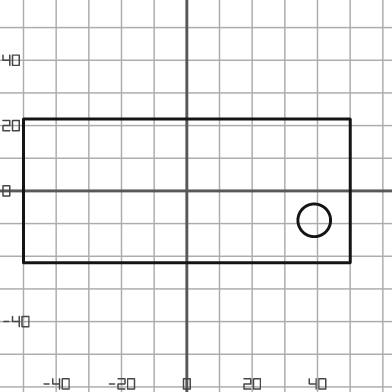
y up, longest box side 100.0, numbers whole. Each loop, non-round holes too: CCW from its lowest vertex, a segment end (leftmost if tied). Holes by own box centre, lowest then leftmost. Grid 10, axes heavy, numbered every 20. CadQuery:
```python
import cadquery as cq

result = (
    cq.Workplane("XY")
    .moveTo(-50.0, -22.0)
    .lineTo(50.0, -22.0)
    .lineTo(50.0, 22.0)
    .lineTo(-50.0, 22.0)
    .close()
    .moveTo(39.0, -9.0)
    .circle(5.0)
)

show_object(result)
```